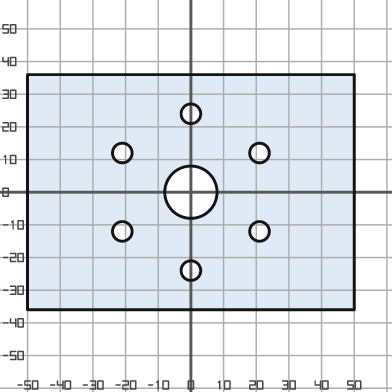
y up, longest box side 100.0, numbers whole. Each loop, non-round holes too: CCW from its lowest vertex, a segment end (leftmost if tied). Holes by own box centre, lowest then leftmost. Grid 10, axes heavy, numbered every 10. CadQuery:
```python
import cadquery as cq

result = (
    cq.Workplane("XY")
    .moveTo(-50.0, -36.0)
    .lineTo(50.0, -36.0)
    .lineTo(50.0, 36.0)
    .lineTo(-50.0, 36.0)
    .close()
    .moveTo(0.0, -24.0)
    .circle(3.0)
    .moveTo(-21.0, -12.0)
    .circle(3.0)
    .moveTo(21.0, -12.0)
    .circle(3.0)
    .moveTo(0.0, 0.0)
    .circle(8.0)
    .moveTo(-21.0, 12.0)
    .circle(3.0)
    .moveTo(21.0, 12.0)
    .circle(3.0)
    .moveTo(0.0, 24.0)
    .circle(3.0)
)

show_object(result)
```